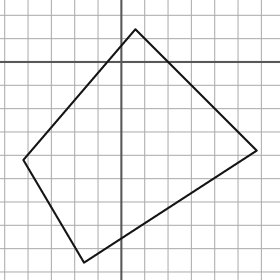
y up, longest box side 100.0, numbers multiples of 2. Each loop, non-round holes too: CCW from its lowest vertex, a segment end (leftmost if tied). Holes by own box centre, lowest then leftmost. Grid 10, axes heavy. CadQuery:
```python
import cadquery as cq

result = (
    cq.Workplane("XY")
    .moveTo(-16.0, -86.0)
    .lineTo(58.0, -38.0)
    .lineTo(6.0, 14.0)
    .lineTo(-42.0, -42.0)
    .close()
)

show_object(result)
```